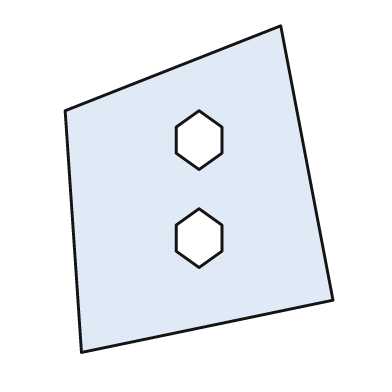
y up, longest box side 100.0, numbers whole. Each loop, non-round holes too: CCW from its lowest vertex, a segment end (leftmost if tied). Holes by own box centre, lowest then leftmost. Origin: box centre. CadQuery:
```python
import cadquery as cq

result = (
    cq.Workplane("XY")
    .moveTo(-36.0, -50.0)
    .lineTo(41.0, -34.0)
    .lineTo(25.0, 50.0)
    .lineTo(-41.0, 24.0)
    .close()
    .moveTo(0.0, -24.0)
    .lineTo(7.0, -19.0)
    .lineTo(7.0, -11.0)
    .lineTo(0.0, -6.0)
    .lineTo(-7.0, -11.0)
    .lineTo(-7.0, -19.0)
    .close()
    .moveTo(0.0, 6.0)
    .lineTo(7.0, 11.0)
    .lineTo(7.0, 19.0)
    .lineTo(0.0, 24.0)
    .lineTo(-7.0, 19.0)
    .lineTo(-7.0, 11.0)
    .close()
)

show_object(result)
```